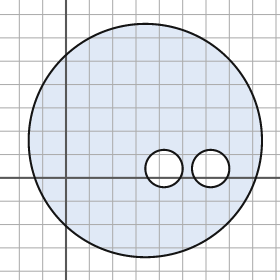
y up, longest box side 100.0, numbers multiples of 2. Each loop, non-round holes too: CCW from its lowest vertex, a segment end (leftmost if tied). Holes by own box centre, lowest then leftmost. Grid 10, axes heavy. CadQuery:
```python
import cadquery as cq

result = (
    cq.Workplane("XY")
    .moveTo(34.0, 16.0)
    .circle(50.0)
    .moveTo(42.0, 4.0)
    .circle(8.0)
    .moveTo(62.0, 4.0)
    .circle(8.0)
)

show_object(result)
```